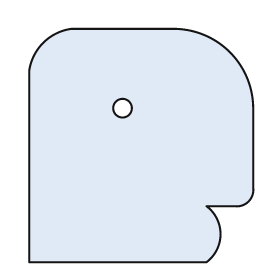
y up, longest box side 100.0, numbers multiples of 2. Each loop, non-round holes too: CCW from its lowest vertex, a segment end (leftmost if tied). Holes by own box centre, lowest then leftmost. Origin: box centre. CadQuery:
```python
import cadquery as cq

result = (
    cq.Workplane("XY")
    .moveTo(-48.0, -50.0)
    .lineTo(28.0, -50.0)
    .threePointArc((34.0, -38.0), (28.0, -26.0))
    .lineTo(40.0, -26.0)
    .threePointArc((46.0, -24.0), (48.0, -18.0))
    .lineTo(48.0, 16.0)
    .threePointArc((38.0, 40.0), (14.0, 50.0))
    .lineTo(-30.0, 50.0)
    .threePointArc((-42.0, 44.0), (-48.0, 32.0))
    .close()
    .moveTo(-8.0, 16.0)
    .circle(4.0)
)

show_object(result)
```